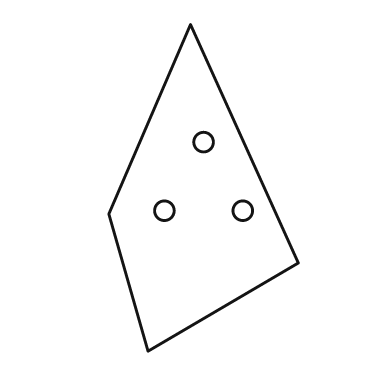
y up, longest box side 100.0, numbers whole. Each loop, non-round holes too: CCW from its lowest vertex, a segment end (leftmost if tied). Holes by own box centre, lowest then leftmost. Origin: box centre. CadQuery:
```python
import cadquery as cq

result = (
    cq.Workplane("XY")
    .moveTo(-17.0, -50.0)
    .lineTo(29.0, -23.0)
    .lineTo(-4.0, 50.0)
    .lineTo(-29.0, -8.0)
    .close()
    .moveTo(-12.0, -7.0)
    .circle(3.0)
    .moveTo(12.0, -7.0)
    .circle(3.0)
    .moveTo(0.0, 14.0)
    .circle(3.0)
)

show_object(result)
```